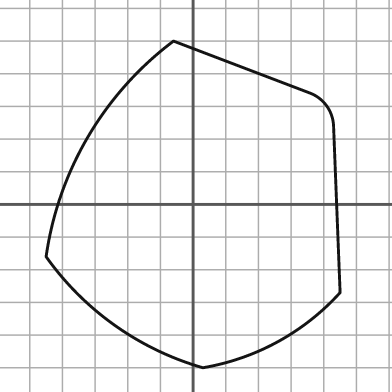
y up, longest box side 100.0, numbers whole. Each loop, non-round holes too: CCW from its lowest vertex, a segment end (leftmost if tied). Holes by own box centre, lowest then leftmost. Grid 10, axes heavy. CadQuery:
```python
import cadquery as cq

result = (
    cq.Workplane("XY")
    .moveTo(3.0, -50.0)
    .threePointArc((26.0, -42.0), (45.0, -27.0))
    .lineTo(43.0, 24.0)
    .threePointArc((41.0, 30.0), (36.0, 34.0))
    .lineTo(-6.0, 50.0)
    .threePointArc((-32.0, 21.0), (-45.0, -16.0))
    .threePointArc((-24.0, -37.0), (3.0, -50.0))
    .close()
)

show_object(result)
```